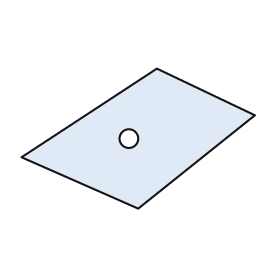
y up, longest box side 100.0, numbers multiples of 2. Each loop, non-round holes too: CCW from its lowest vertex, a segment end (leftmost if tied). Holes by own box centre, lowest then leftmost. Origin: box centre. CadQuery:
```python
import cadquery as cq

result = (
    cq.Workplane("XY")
    .moveTo(0.0, -30.0)
    .lineTo(50.0, 10.0)
    .lineTo(8.0, 30.0)
    .lineTo(-50.0, -8.0)
    .close()
    .moveTo(-4.0, 0.0)
    .circle(4.0)
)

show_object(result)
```